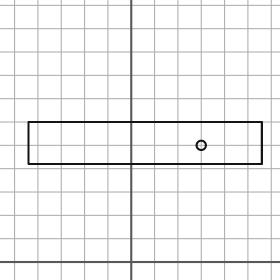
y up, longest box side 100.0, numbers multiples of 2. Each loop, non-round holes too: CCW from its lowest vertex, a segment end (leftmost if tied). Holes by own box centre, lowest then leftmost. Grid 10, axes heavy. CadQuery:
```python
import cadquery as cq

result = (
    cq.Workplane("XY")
    .moveTo(-44.0, 42.0)
    .lineTo(56.0, 42.0)
    .lineTo(56.0, 60.0)
    .lineTo(-44.0, 60.0)
    .close()
    .moveTo(30.0, 50.0)
    .circle(2.0)
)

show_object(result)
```